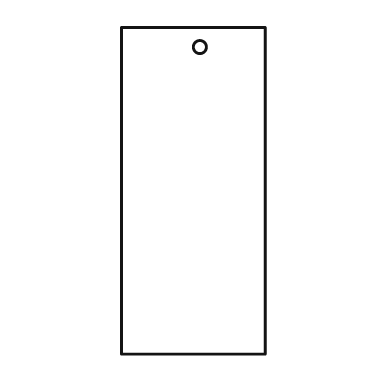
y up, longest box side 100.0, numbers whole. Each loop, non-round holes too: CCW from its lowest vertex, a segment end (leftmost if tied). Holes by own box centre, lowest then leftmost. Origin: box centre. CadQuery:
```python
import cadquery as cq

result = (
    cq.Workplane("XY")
    .moveTo(-22.0, -50.0)
    .lineTo(22.0, -50.0)
    .lineTo(22.0, 50.0)
    .lineTo(-22.0, 50.0)
    .close()
    .moveTo(2.0, 44.0)
    .circle(2.0)
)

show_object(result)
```